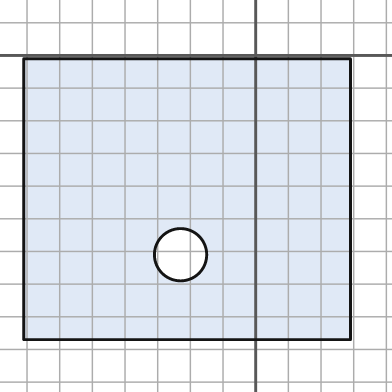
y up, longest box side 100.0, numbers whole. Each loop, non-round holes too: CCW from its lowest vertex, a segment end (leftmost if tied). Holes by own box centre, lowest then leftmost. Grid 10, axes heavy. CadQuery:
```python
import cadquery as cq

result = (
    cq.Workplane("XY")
    .moveTo(-71.0, -87.0)
    .lineTo(29.0, -87.0)
    .lineTo(29.0, -1.0)
    .lineTo(-71.0, -1.0)
    .close()
    .moveTo(-23.0, -61.0)
    .circle(8.0)
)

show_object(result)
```